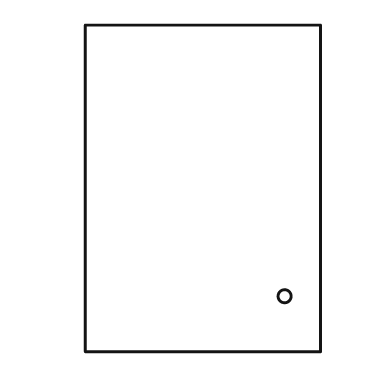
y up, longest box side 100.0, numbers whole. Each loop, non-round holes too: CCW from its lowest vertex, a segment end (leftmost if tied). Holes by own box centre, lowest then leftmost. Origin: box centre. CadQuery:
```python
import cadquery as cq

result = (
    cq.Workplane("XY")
    .moveTo(-36.0, -50.0)
    .lineTo(36.0, -50.0)
    .lineTo(36.0, 50.0)
    .lineTo(-36.0, 50.0)
    .close()
    .moveTo(25.0, -33.0)
    .circle(2.0)
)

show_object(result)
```